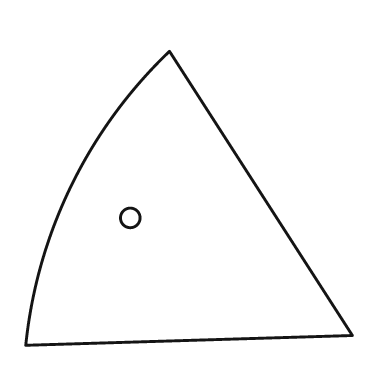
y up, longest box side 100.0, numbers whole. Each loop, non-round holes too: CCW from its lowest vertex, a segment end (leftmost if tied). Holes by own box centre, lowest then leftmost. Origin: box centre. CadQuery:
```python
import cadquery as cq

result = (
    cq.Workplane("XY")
    .moveTo(-50.0, -45.0)
    .lineTo(50.0, -42.0)
    .lineTo(-6.0, 45.0)
    .threePointArc((-36.0, 4.0), (-50.0, -45.0))
    .close()
    .moveTo(-18.0, -6.0)
    .circle(3.0)
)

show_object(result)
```